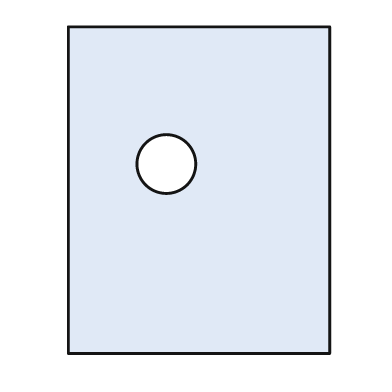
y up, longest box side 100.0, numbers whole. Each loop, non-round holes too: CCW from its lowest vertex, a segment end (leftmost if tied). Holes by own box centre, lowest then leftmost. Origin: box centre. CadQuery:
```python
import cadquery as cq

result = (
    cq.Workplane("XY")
    .moveTo(-40.0, -50.0)
    .lineTo(40.0, -50.0)
    .lineTo(40.0, 50.0)
    .lineTo(-40.0, 50.0)
    .close()
    .moveTo(-10.0, 8.0)
    .circle(9.0)
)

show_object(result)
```